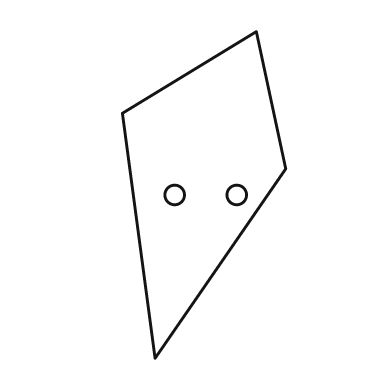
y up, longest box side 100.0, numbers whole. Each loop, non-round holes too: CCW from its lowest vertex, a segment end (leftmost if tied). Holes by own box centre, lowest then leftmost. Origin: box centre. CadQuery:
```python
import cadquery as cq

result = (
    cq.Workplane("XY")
    .moveTo(-15.0, -50.0)
    .lineTo(25.0, 8.0)
    .lineTo(16.0, 50.0)
    .lineTo(-25.0, 25.0)
    .close()
    .moveTo(-9.0, 0.0)
    .circle(3.0)
    .moveTo(10.0, 0.0)
    .circle(3.0)
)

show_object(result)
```